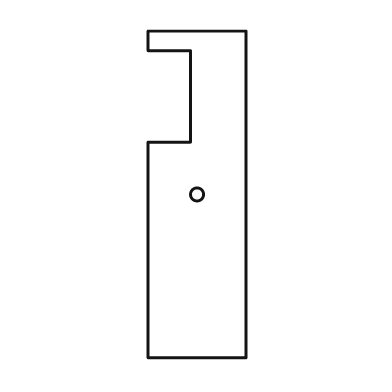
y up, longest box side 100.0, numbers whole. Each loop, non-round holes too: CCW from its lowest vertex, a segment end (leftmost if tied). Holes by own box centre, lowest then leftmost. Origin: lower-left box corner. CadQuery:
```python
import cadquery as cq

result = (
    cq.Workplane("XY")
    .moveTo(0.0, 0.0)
    .lineTo(30.0, 0.0)
    .lineTo(30.0, 100.0)
    .lineTo(0.0, 100.0)
    .lineTo(0.0, 94.0)
    .lineTo(13.0, 94.0)
    .lineTo(13.0, 66.0)
    .lineTo(0.0, 66.0)
    .close()
    .moveTo(15.0, 50.0)
    .circle(2.0)
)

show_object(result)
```